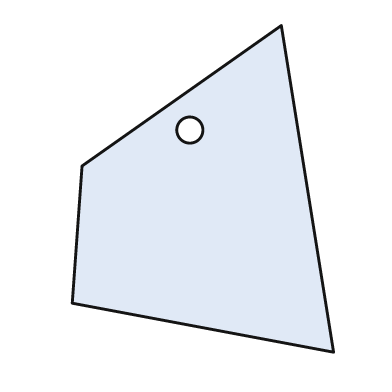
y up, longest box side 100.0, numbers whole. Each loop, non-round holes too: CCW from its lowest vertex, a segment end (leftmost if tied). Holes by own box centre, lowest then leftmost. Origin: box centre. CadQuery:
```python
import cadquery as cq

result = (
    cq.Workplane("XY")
    .moveTo(40.0, -50.0)
    .lineTo(24.0, 50.0)
    .lineTo(-37.0, 7.0)
    .lineTo(-40.0, -35.0)
    .close()
    .moveTo(-4.0, 18.0)
    .circle(4.0)
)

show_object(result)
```